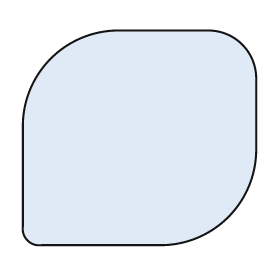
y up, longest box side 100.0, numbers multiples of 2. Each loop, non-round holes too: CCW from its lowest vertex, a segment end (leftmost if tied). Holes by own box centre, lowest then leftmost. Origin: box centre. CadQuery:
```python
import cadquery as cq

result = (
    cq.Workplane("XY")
    .moveTo(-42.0, -46.0)
    .lineTo(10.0, -46.0)
    .threePointArc((38.0, -34.0), (50.0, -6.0))
    .lineTo(50.0, 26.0)
    .threePointArc((44.0, 40.0), (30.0, 46.0))
    .lineTo(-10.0, 46.0)
    .threePointArc((-38.0, 34.0), (-50.0, 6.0))
    .lineTo(-50.0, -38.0)
    .threePointArc((-48.0, -44.0), (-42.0, -46.0))
    .close()
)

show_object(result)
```